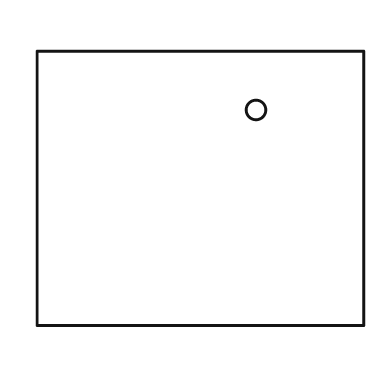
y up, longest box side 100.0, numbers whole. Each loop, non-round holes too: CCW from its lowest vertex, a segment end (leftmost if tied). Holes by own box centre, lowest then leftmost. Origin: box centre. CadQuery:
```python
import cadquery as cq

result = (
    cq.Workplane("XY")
    .moveTo(-50.0, -42.0)
    .lineTo(50.0, -42.0)
    .lineTo(50.0, 42.0)
    .lineTo(-50.0, 42.0)
    .close()
    .moveTo(17.0, 24.0)
    .circle(3.0)
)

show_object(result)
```